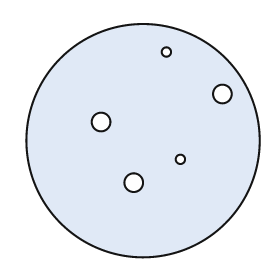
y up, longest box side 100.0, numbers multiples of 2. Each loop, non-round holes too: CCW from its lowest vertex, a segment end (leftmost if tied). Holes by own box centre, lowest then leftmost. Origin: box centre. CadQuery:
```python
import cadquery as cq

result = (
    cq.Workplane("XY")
    .moveTo(0.0, 0.0)
    .circle(50.0)
    .moveTo(-4.0, -18.0)
    .circle(4.0)
    .moveTo(16.0, -8.0)
    .circle(2.0)
    .moveTo(-18.0, 8.0)
    .circle(4.0)
    .moveTo(34.0, 20.0)
    .circle(4.0)
    .moveTo(10.0, 38.0)
    .circle(2.0)
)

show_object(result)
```